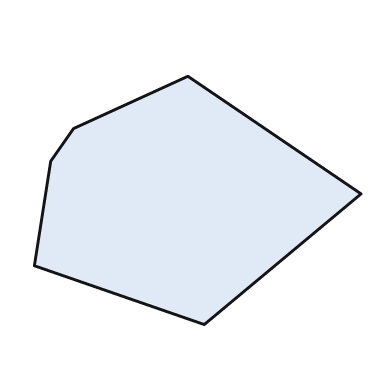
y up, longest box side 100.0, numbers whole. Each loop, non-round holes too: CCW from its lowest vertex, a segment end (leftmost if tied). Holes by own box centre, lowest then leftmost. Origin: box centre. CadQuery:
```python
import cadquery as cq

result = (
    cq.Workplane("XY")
    .moveTo(2.0, -38.0)
    .lineTo(50.0, 2.0)
    .lineTo(-3.0, 38.0)
    .lineTo(-38.0, 22.0)
    .lineTo(-45.0, 12.0)
    .lineTo(-50.0, -20.0)
    .close()
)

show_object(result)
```